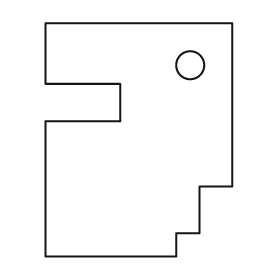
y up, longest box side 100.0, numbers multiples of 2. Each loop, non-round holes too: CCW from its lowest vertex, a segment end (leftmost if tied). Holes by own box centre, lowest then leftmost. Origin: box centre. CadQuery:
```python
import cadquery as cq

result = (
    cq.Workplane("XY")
    .moveTo(-40.0, -50.0)
    .lineTo(16.0, -50.0)
    .lineTo(16.0, -40.0)
    .lineTo(26.0, -40.0)
    .lineTo(26.0, -20.0)
    .lineTo(40.0, -20.0)
    .lineTo(40.0, 50.0)
    .lineTo(-40.0, 50.0)
    .lineTo(-40.0, 24.0)
    .lineTo(-8.0, 24.0)
    .lineTo(-8.0, 8.0)
    .lineTo(-40.0, 8.0)
    .close()
    .moveTo(22.0, 32.0)
    .circle(6.0)
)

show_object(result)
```